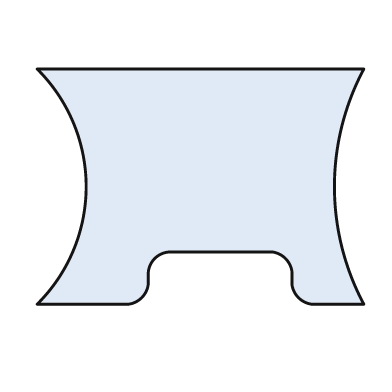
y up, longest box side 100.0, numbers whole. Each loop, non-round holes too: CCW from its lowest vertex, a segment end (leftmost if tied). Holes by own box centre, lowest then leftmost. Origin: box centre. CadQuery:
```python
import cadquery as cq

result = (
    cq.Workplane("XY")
    .moveTo(-50.0, -36.0)
    .lineTo(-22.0, -36.0)
    .threePointArc((-18.0, -34.0), (-16.0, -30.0))
    .lineTo(-16.0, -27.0)
    .threePointArc((-14.0, -22.0), (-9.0, -20.0))
    .lineTo(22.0, -20.0)
    .threePointArc((26.0, -22.0), (28.0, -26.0))
    .lineTo(28.0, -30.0)
    .threePointArc((30.0, -34.0), (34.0, -36.0))
    .lineTo(50.0, -36.0)
    .threePointArc((41.0, 0.0), (50.0, 36.0))
    .lineTo(-50.0, 36.0)
    .threePointArc((-35.0, 0.0), (-50.0, -36.0))
    .close()
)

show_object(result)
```